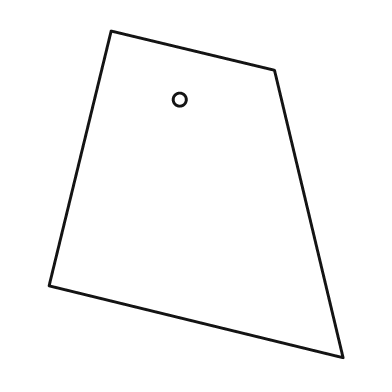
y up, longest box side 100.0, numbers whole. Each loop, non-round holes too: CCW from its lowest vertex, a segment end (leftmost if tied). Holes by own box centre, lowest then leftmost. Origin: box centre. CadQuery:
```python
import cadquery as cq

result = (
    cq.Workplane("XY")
    .moveTo(45.0, -50.0)
    .lineTo(24.0, 38.0)
    .lineTo(-26.0, 50.0)
    .lineTo(-45.0, -28.0)
    .close()
    .moveTo(-5.0, 29.0)
    .circle(2.0)
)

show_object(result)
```